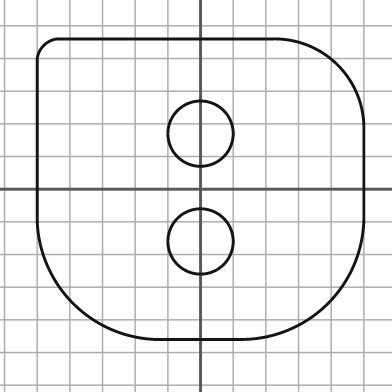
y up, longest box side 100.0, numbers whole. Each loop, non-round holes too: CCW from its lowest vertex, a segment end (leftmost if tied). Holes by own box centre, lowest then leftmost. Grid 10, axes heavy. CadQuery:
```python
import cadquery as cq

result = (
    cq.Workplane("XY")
    .moveTo(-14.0, -46.0)
    .lineTo(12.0, -46.0)
    .threePointArc((39.0, -35.0), (50.0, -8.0))
    .lineTo(50.0, 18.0)
    .threePointArc((42.0, 38.0), (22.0, 46.0))
    .lineTo(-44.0, 46.0)
    .threePointArc((-48.0, 44.0), (-50.0, 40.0))
    .lineTo(-50.0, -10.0)
    .threePointArc((-39.0, -35.0), (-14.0, -46.0))
    .close()
    .moveTo(0.0, -16.0)
    .circle(10.0)
    .moveTo(0.0, 17.0)
    .circle(10.0)
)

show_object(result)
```